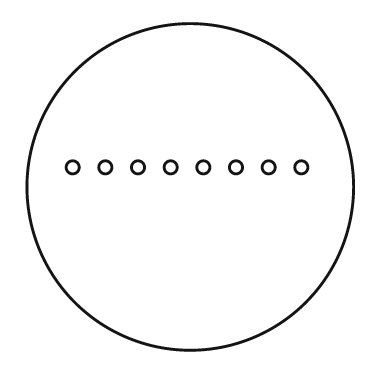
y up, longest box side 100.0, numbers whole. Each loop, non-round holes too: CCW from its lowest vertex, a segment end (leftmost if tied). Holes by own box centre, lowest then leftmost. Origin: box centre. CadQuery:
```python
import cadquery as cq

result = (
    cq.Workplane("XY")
    .moveTo(0.0, 0.0)
    .circle(50.0)
    .moveTo(-36.0, 6.0)
    .circle(2.0)
    .moveTo(-26.0, 6.0)
    .circle(2.0)
    .moveTo(-16.0, 6.0)
    .circle(2.0)
    .moveTo(-6.0, 6.0)
    .circle(2.0)
    .moveTo(4.0, 6.0)
    .circle(2.0)
    .moveTo(14.0, 6.0)
    .circle(2.0)
    .moveTo(24.0, 6.0)
    .circle(2.0)
    .moveTo(34.0, 6.0)
    .circle(2.0)
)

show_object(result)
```